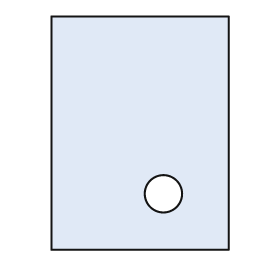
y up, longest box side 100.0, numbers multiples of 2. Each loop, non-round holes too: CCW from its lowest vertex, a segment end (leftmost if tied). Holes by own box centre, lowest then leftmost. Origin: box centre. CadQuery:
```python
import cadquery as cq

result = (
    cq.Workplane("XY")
    .moveTo(-38.0, -50.0)
    .lineTo(38.0, -50.0)
    .lineTo(38.0, 50.0)
    .lineTo(-38.0, 50.0)
    .close()
    .moveTo(10.0, -26.0)
    .circle(8.0)
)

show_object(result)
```